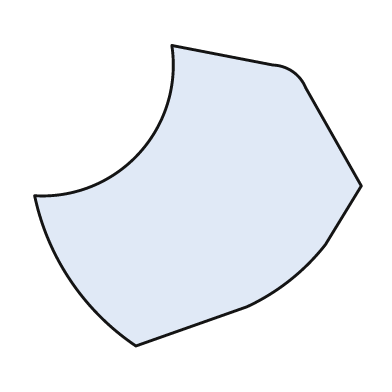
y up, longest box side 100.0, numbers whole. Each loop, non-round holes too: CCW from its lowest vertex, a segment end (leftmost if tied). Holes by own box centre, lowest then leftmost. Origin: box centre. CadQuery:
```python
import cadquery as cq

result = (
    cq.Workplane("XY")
    .moveTo(-19.0, -46.0)
    .lineTo(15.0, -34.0)
    .threePointArc((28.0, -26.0), (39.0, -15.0))
    .lineTo(50.0, 3.0)
    .lineTo(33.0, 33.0)
    .threePointArc((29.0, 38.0), (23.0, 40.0))
    .lineTo(-8.0, 46.0)
    .threePointArc((-18.0, 13.0), (-50.0, 0.0))
    .threePointArc((-39.0, -26.0), (-19.0, -46.0))
    .close()
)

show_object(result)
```